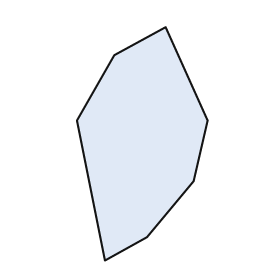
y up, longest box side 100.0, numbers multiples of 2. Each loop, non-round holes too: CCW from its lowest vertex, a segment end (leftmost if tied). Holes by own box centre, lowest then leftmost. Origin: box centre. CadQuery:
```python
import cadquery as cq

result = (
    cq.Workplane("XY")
    .moveTo(-16.0, -50.0)
    .lineTo(2.0, -40.0)
    .lineTo(22.0, -16.0)
    .lineTo(28.0, 10.0)
    .lineTo(10.0, 50.0)
    .lineTo(-12.0, 38.0)
    .lineTo(-28.0, 10.0)
    .close()
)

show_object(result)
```